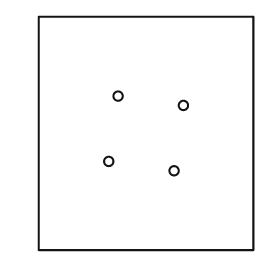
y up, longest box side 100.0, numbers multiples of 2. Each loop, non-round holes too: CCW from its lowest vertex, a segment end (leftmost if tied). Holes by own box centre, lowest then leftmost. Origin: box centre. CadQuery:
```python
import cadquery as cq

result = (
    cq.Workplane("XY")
    .moveTo(-46.0, -50.0)
    .lineTo(46.0, -50.0)
    .lineTo(46.0, 50.0)
    .lineTo(-46.0, 50.0)
    .close()
    .moveTo(12.0, -16.0)
    .circle(2.0)
    .moveTo(-16.0, -12.0)
    .circle(2.0)
    .moveTo(16.0, 12.0)
    .circle(2.0)
    .moveTo(-12.0, 16.0)
    .circle(2.0)
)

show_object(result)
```